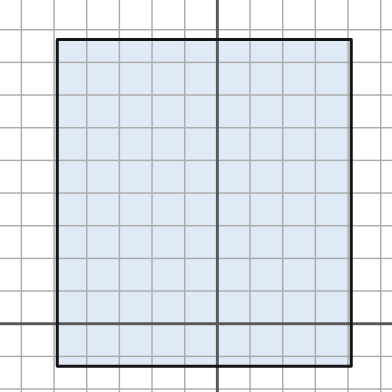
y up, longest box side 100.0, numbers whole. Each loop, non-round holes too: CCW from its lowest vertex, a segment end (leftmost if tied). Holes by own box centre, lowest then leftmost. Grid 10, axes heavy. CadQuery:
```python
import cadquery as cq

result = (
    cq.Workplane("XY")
    .moveTo(-49.0, -13.0)
    .lineTo(41.0, -13.0)
    .lineTo(41.0, 87.0)
    .lineTo(-49.0, 87.0)
    .close()
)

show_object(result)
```